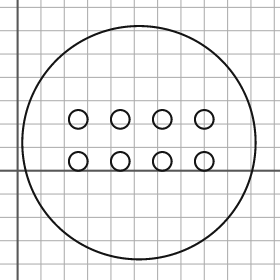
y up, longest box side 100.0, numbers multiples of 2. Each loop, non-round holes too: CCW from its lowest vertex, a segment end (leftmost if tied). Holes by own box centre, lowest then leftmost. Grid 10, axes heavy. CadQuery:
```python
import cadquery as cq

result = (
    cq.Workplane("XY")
    .moveTo(52.0, 12.0)
    .circle(50.0)
    .moveTo(26.0, 4.0)
    .circle(4.0)
    .moveTo(44.0, 4.0)
    .circle(4.0)
    .moveTo(62.0, 4.0)
    .circle(4.0)
    .moveTo(80.0, 4.0)
    .circle(4.0)
    .moveTo(26.0, 22.0)
    .circle(4.0)
    .moveTo(44.0, 22.0)
    .circle(4.0)
    .moveTo(62.0, 22.0)
    .circle(4.0)
    .moveTo(80.0, 22.0)
    .circle(4.0)
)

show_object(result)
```